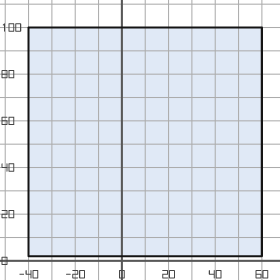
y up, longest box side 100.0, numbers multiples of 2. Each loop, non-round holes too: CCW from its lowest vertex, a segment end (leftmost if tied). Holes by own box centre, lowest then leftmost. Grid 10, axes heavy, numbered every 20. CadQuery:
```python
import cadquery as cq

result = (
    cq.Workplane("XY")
    .moveTo(-40.0, 2.0)
    .lineTo(60.0, 2.0)
    .lineTo(60.0, 100.0)
    .lineTo(-40.0, 100.0)
    .close()
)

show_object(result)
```